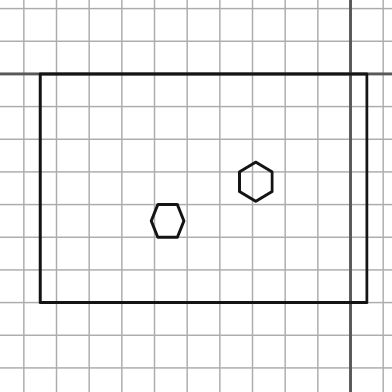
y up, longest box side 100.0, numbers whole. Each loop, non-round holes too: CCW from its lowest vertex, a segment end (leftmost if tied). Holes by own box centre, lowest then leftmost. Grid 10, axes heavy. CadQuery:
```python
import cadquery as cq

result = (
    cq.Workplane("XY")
    .moveTo(-95.0, -70.0)
    .lineTo(5.0, -70.0)
    .lineTo(5.0, 0.0)
    .lineTo(-95.0, 0.0)
    .close()
    .moveTo(-59.0, -50.0)
    .lineTo(-53.0, -50.0)
    .lineTo(-51.0, -45.0)
    .lineTo(-53.0, -40.0)
    .lineTo(-59.0, -40.0)
    .lineTo(-61.0, -45.0)
    .close()
    .moveTo(-29.0, -39.0)
    .lineTo(-24.0, -36.0)
    .lineTo(-24.0, -30.0)
    .lineTo(-29.0, -27.0)
    .lineTo(-34.0, -30.0)
    .lineTo(-34.0, -36.0)
    .close()
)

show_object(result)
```